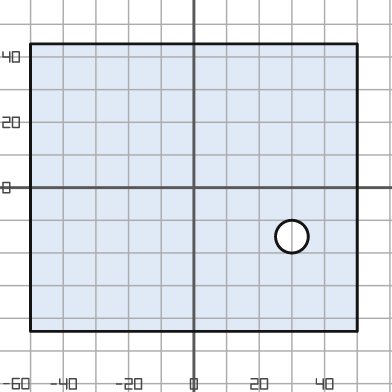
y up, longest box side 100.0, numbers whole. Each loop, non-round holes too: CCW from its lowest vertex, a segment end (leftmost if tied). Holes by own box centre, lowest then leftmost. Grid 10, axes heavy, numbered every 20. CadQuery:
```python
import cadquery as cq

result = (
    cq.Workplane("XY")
    .moveTo(-50.0, -44.0)
    .lineTo(50.0, -44.0)
    .lineTo(50.0, 44.0)
    .lineTo(-50.0, 44.0)
    .close()
    .moveTo(30.0, -15.0)
    .circle(5.0)
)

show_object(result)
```